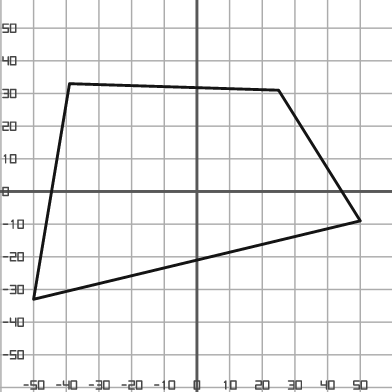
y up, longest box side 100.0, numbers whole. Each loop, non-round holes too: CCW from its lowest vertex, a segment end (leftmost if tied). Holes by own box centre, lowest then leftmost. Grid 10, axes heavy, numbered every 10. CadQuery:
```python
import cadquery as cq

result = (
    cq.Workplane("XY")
    .moveTo(-50.0, -33.0)
    .lineTo(50.0, -9.0)
    .lineTo(25.0, 31.0)
    .lineTo(-39.0, 33.0)
    .close()
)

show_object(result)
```